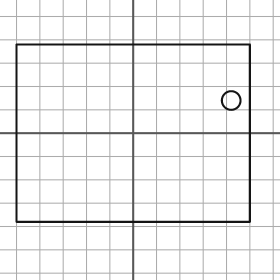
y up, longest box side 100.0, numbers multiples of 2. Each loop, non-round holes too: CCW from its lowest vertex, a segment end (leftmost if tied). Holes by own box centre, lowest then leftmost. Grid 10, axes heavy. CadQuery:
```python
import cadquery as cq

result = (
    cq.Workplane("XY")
    .moveTo(-50.0, -38.0)
    .lineTo(50.0, -38.0)
    .lineTo(50.0, 38.0)
    .lineTo(-50.0, 38.0)
    .close()
    .moveTo(42.0, 14.0)
    .circle(4.0)
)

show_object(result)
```